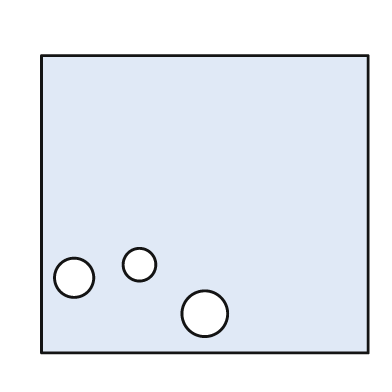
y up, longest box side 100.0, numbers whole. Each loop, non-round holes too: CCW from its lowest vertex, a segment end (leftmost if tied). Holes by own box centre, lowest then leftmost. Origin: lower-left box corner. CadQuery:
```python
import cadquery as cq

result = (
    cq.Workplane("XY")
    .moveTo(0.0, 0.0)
    .lineTo(100.0, 0.0)
    .lineTo(100.0, 91.0)
    .lineTo(0.0, 91.0)
    .close()
    .moveTo(50.0, 12.0)
    .circle(7.0)
    .moveTo(10.0, 23.0)
    .circle(6.0)
    .moveTo(30.0, 27.0)
    .circle(5.0)
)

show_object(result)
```